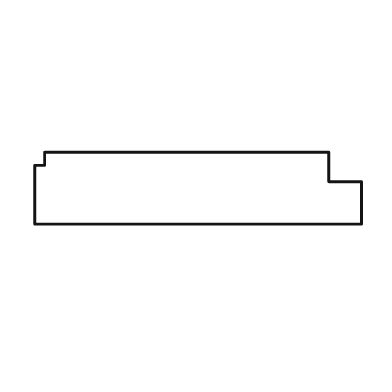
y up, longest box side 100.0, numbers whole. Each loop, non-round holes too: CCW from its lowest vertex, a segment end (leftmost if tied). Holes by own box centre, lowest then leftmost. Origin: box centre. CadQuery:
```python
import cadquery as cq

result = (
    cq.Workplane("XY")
    .moveTo(-50.0, -11.0)
    .lineTo(50.0, -11.0)
    .lineTo(50.0, 2.0)
    .lineTo(40.0, 2.0)
    .lineTo(40.0, 11.0)
    .lineTo(-47.0, 11.0)
    .lineTo(-47.0, 7.0)
    .lineTo(-50.0, 7.0)
    .close()
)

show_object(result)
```